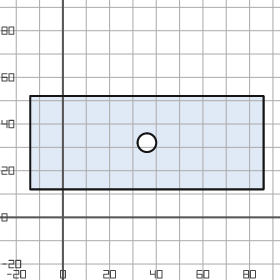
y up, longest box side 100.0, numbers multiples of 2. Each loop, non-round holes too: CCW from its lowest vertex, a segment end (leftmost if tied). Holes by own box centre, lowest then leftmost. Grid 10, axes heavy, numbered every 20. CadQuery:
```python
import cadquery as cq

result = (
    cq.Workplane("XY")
    .moveTo(-14.0, 12.0)
    .lineTo(86.0, 12.0)
    .lineTo(86.0, 52.0)
    .lineTo(-14.0, 52.0)
    .close()
    .moveTo(36.0, 32.0)
    .circle(4.0)
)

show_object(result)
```